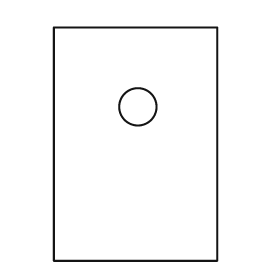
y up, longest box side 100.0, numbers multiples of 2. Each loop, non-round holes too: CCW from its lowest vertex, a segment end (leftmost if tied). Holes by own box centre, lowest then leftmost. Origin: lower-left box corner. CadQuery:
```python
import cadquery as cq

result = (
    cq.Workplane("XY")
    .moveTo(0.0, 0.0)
    .lineTo(70.0, 0.0)
    .lineTo(70.0, 100.0)
    .lineTo(0.0, 100.0)
    .close()
    .moveTo(36.0, 66.0)
    .circle(8.0)
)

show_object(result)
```